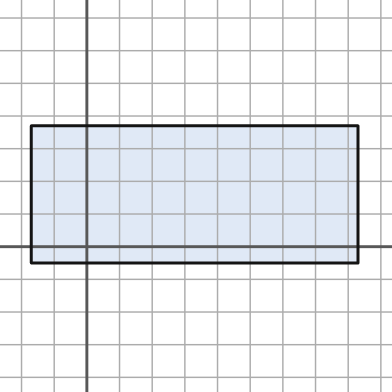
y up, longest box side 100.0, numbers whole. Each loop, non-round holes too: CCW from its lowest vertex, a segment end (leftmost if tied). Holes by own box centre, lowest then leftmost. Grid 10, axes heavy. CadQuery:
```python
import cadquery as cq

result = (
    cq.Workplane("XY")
    .moveTo(-17.0, -5.0)
    .lineTo(83.0, -5.0)
    .lineTo(83.0, 37.0)
    .lineTo(-17.0, 37.0)
    .close()
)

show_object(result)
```